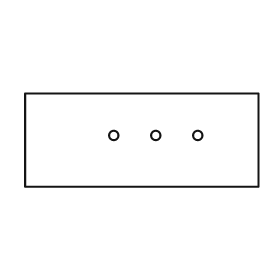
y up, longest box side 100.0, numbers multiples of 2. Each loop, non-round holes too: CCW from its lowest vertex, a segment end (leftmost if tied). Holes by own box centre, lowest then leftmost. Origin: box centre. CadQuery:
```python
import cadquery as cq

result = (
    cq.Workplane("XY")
    .moveTo(-50.0, -20.0)
    .lineTo(50.0, -20.0)
    .lineTo(50.0, 20.0)
    .lineTo(-50.0, 20.0)
    .close()
    .moveTo(-12.0, 2.0)
    .circle(2.0)
    .moveTo(6.0, 2.0)
    .circle(2.0)
    .moveTo(24.0, 2.0)
    .circle(2.0)
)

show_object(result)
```